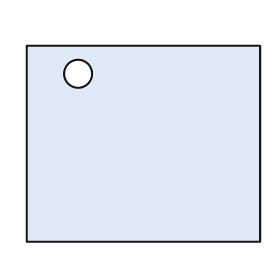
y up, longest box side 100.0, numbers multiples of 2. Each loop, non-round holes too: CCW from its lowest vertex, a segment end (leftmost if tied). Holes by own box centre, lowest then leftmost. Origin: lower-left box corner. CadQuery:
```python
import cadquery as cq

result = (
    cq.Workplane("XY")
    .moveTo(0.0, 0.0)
    .lineTo(100.0, 0.0)
    .lineTo(100.0, 84.0)
    .lineTo(0.0, 84.0)
    .close()
    .moveTo(22.0, 72.0)
    .circle(6.0)
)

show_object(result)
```